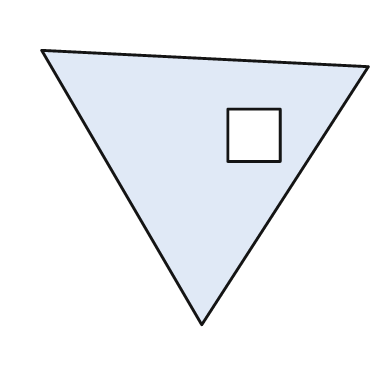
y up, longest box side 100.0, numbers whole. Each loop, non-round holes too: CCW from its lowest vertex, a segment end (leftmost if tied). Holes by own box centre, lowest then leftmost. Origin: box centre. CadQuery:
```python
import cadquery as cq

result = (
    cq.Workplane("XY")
    .moveTo(-1.0, -42.0)
    .lineTo(50.0, 37.0)
    .lineTo(-50.0, 42.0)
    .close()
    .moveTo(7.0, 8.0)
    .lineTo(23.0, 8.0)
    .lineTo(23.0, 24.0)
    .lineTo(7.0, 24.0)
    .close()
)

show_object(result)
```